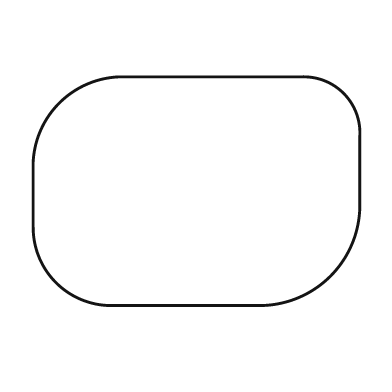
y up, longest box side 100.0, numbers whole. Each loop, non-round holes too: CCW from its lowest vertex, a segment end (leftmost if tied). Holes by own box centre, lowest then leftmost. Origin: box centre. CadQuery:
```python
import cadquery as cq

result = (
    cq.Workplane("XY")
    .moveTo(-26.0, -35.0)
    .lineTo(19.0, -35.0)
    .threePointArc((41.0, -26.0), (50.0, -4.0))
    .lineTo(50.0, 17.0)
    .threePointArc((45.0, 30.0), (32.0, 35.0))
    .lineTo(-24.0, 35.0)
    .threePointArc((-42.0, 27.0), (-50.0, 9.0))
    .lineTo(-50.0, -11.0)
    .threePointArc((-43.0, -28.0), (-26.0, -35.0))
    .close()
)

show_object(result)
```